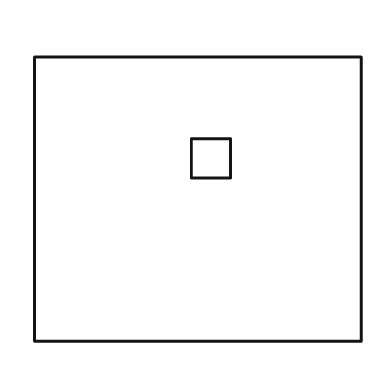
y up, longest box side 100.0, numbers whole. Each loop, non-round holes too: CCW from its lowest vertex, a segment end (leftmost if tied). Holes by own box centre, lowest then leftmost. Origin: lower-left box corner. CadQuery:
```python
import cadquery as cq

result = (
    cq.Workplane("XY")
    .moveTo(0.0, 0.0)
    .lineTo(100.0, 0.0)
    .lineTo(100.0, 87.0)
    .lineTo(0.0, 87.0)
    .close()
    .moveTo(48.0, 50.0)
    .lineTo(60.0, 50.0)
    .lineTo(60.0, 62.0)
    .lineTo(48.0, 62.0)
    .close()
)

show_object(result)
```